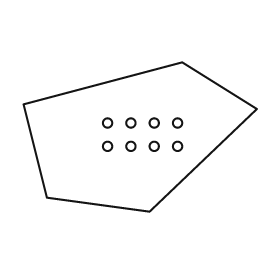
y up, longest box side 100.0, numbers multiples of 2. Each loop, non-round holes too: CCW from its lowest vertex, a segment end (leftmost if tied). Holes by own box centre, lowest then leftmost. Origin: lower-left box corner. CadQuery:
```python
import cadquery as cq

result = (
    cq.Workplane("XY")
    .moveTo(54.0, 0.0)
    .lineTo(100.0, 44.0)
    .lineTo(68.0, 64.0)
    .lineTo(0.0, 46.0)
    .lineTo(10.0, 6.0)
    .close()
    .moveTo(36.0, 28.0)
    .circle(2.0)
    .moveTo(46.0, 28.0)
    .circle(2.0)
    .moveTo(56.0, 28.0)
    .circle(2.0)
    .moveTo(66.0, 28.0)
    .circle(2.0)
    .moveTo(36.0, 38.0)
    .circle(2.0)
    .moveTo(46.0, 38.0)
    .circle(2.0)
    .moveTo(56.0, 38.0)
    .circle(2.0)
    .moveTo(66.0, 38.0)
    .circle(2.0)
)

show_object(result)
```